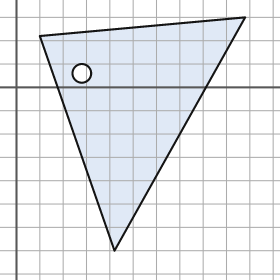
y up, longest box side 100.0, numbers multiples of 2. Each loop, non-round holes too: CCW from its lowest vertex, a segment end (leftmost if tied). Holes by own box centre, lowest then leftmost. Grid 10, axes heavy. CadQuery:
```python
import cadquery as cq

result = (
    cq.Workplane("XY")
    .moveTo(42.0, -70.0)
    .lineTo(98.0, 30.0)
    .lineTo(10.0, 22.0)
    .close()
    .moveTo(28.0, 6.0)
    .circle(4.0)
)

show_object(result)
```